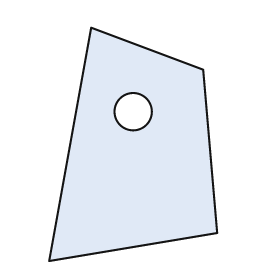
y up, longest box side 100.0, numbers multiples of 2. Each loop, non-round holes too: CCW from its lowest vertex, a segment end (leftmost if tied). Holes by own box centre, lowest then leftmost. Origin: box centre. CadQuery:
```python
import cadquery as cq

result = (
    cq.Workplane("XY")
    .moveTo(-36.0, -50.0)
    .lineTo(36.0, -38.0)
    .lineTo(30.0, 32.0)
    .lineTo(-18.0, 50.0)
    .close()
    .moveTo(0.0, 14.0)
    .circle(8.0)
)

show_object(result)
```